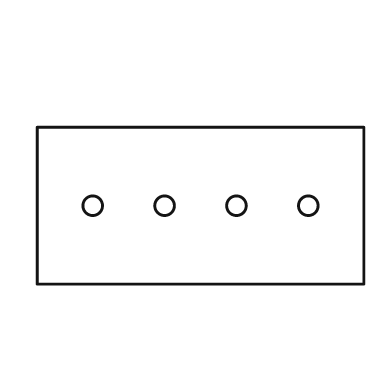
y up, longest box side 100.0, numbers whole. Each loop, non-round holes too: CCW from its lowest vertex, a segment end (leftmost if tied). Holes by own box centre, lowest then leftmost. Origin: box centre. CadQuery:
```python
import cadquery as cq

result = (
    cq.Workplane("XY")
    .moveTo(-50.0, -24.0)
    .lineTo(50.0, -24.0)
    .lineTo(50.0, 24.0)
    .lineTo(-50.0, 24.0)
    .close()
    .moveTo(-33.0, 0.0)
    .circle(3.0)
    .moveTo(-11.0, 0.0)
    .circle(3.0)
    .moveTo(11.0, 0.0)
    .circle(3.0)
    .moveTo(33.0, 0.0)
    .circle(3.0)
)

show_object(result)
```